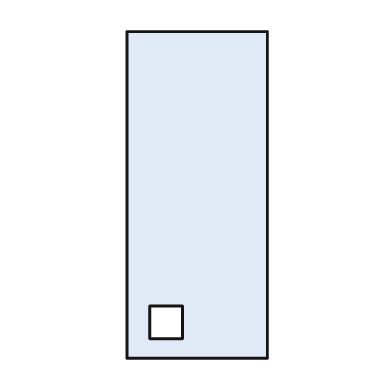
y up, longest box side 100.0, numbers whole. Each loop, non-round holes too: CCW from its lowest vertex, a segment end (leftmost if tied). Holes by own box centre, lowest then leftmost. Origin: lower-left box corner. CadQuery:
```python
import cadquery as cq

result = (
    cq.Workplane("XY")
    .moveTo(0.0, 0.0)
    .lineTo(43.0, 0.0)
    .lineTo(43.0, 100.0)
    .lineTo(0.0, 100.0)
    .close()
    .moveTo(7.0, 6.0)
    .lineTo(17.0, 6.0)
    .lineTo(17.0, 16.0)
    .lineTo(7.0, 16.0)
    .close()
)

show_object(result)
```